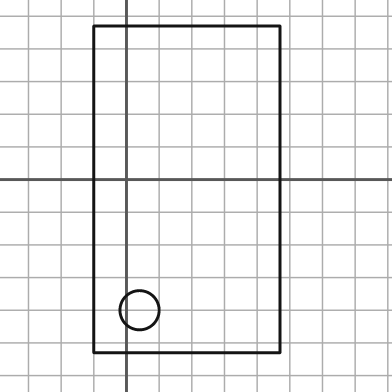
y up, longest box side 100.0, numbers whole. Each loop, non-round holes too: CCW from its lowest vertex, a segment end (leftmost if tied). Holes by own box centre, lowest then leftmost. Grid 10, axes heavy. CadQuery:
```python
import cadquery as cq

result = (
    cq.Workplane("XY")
    .moveTo(-10.0, -53.0)
    .lineTo(47.0, -53.0)
    .lineTo(47.0, 47.0)
    .lineTo(-10.0, 47.0)
    .close()
    .moveTo(4.0, -40.0)
    .circle(6.0)
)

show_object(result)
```